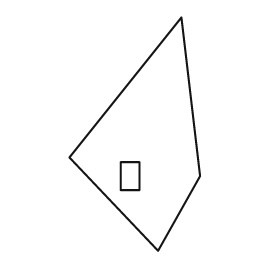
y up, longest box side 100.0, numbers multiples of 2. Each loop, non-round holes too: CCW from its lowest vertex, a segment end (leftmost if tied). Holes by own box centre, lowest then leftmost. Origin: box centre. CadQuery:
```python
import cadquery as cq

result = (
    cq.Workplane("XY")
    .moveTo(10.0, -50.0)
    .lineTo(28.0, -18.0)
    .lineTo(20.0, 50.0)
    .lineTo(-28.0, -10.0)
    .close()
    .moveTo(-6.0, -24.0)
    .lineTo(2.0, -24.0)
    .lineTo(2.0, -12.0)
    .lineTo(-6.0, -12.0)
    .close()
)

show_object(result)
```